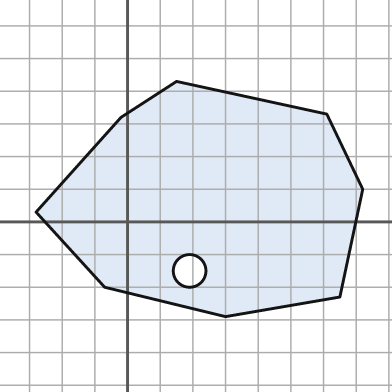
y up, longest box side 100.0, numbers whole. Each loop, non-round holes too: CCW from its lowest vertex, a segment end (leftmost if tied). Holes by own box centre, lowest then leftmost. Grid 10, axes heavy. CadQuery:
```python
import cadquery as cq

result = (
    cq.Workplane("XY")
    .moveTo(30.0, -29.0)
    .lineTo(65.0, -23.0)
    .lineTo(72.0, 10.0)
    .lineTo(61.0, 33.0)
    .lineTo(15.0, 43.0)
    .lineTo(-2.0, 32.0)
    .lineTo(-28.0, 3.0)
    .lineTo(-7.0, -20.0)
    .close()
    .moveTo(19.0, -15.0)
    .circle(5.0)
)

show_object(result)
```